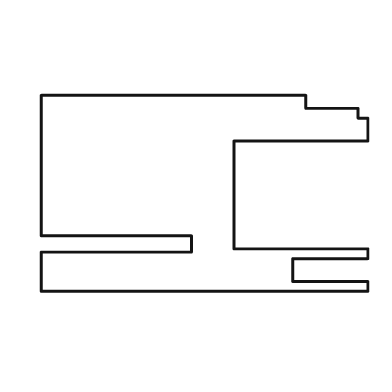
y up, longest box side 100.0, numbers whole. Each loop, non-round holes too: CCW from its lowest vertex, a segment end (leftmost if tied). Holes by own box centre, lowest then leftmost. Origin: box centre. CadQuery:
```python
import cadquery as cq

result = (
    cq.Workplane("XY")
    .moveTo(-50.0, -30.0)
    .lineTo(50.0, -30.0)
    .lineTo(50.0, -27.0)
    .lineTo(27.0, -27.0)
    .lineTo(27.0, -20.0)
    .lineTo(50.0, -20.0)
    .lineTo(50.0, -17.0)
    .lineTo(9.0, -17.0)
    .lineTo(9.0, 16.0)
    .lineTo(50.0, 16.0)
    .lineTo(50.0, 23.0)
    .lineTo(47.0, 23.0)
    .lineTo(47.0, 26.0)
    .lineTo(31.0, 26.0)
    .lineTo(31.0, 30.0)
    .lineTo(-50.0, 30.0)
    .lineTo(-50.0, -13.0)
    .lineTo(-4.0, -13.0)
    .lineTo(-4.0, -18.0)
    .lineTo(-50.0, -18.0)
    .close()
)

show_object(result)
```